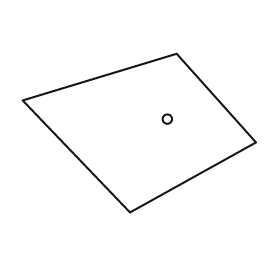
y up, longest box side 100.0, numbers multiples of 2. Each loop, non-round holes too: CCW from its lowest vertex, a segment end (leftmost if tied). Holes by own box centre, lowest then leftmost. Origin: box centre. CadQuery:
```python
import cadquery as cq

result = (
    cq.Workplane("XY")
    .moveTo(-4.0, -34.0)
    .lineTo(50.0, -4.0)
    .lineTo(16.0, 34.0)
    .lineTo(-50.0, 14.0)
    .close()
    .moveTo(12.0, 6.0)
    .circle(2.0)
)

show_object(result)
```